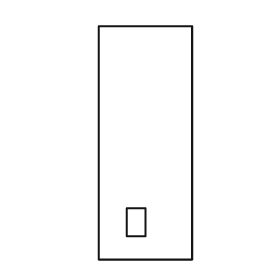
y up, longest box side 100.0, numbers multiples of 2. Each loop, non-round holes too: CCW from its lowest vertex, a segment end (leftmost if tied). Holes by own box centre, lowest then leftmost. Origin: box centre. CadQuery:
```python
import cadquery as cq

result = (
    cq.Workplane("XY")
    .moveTo(-20.0, -50.0)
    .lineTo(20.0, -50.0)
    .lineTo(20.0, 50.0)
    .lineTo(-20.0, 50.0)
    .close()
    .moveTo(-8.0, -40.0)
    .lineTo(0.0, -40.0)
    .lineTo(0.0, -28.0)
    .lineTo(-8.0, -28.0)
    .close()
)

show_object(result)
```